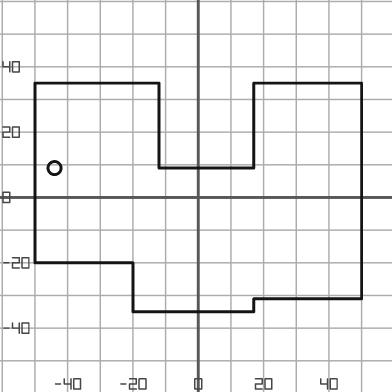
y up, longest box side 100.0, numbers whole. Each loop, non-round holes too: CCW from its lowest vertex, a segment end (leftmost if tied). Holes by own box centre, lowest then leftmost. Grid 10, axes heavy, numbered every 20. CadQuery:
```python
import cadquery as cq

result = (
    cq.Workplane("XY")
    .moveTo(-20.0, -35.0)
    .lineTo(17.0, -35.0)
    .lineTo(17.0, -31.0)
    .lineTo(50.0, -31.0)
    .lineTo(50.0, 35.0)
    .lineTo(17.0, 35.0)
    .lineTo(17.0, 9.0)
    .lineTo(-12.0, 9.0)
    .lineTo(-12.0, 35.0)
    .lineTo(-50.0, 35.0)
    .lineTo(-50.0, -20.0)
    .lineTo(-20.0, -20.0)
    .close()
    .moveTo(-44.0, 9.0)
    .circle(2.0)
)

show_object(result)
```